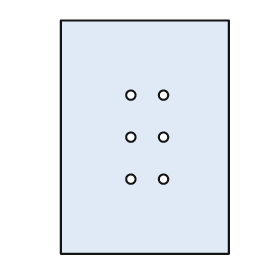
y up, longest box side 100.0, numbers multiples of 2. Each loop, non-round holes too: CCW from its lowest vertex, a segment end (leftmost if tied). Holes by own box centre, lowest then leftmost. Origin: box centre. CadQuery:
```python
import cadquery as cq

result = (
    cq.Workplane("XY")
    .moveTo(-36.0, -50.0)
    .lineTo(36.0, -50.0)
    .lineTo(36.0, 50.0)
    .lineTo(-36.0, 50.0)
    .close()
    .moveTo(-6.0, -18.0)
    .circle(2.0)
    .moveTo(8.0, -18.0)
    .circle(2.0)
    .moveTo(-6.0, 0.0)
    .circle(2.0)
    .moveTo(8.0, 0.0)
    .circle(2.0)
    .moveTo(-6.0, 18.0)
    .circle(2.0)
    .moveTo(8.0, 18.0)
    .circle(2.0)
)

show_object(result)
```